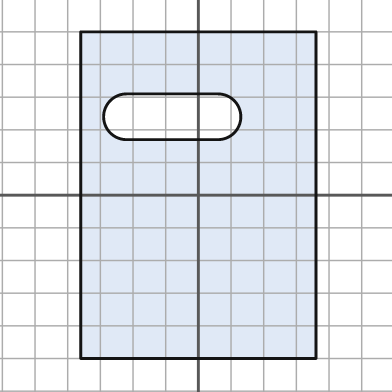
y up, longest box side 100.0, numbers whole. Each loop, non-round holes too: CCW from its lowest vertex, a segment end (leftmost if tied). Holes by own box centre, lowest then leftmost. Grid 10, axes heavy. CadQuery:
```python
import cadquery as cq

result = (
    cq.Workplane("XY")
    .moveTo(-36.0, -50.0)
    .lineTo(36.0, -50.0)
    .lineTo(36.0, 50.0)
    .lineTo(-36.0, 50.0)
    .close()
    .moveTo(-22.0, 17.0)
    .lineTo(6.0, 17.0)
    .threePointArc((13.0, 24.0), (6.0, 31.0))
    .lineTo(-22.0, 31.0)
    .threePointArc((-29.0, 24.0), (-22.0, 17.0))
    .close()
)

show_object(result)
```